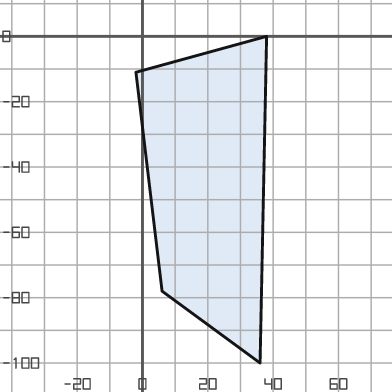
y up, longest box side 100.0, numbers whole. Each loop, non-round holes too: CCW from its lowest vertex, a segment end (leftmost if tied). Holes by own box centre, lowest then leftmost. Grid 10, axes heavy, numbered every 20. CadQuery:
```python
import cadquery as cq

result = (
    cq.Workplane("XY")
    .moveTo(36.0, -100.0)
    .lineTo(38.0, 0.0)
    .lineTo(-2.0, -11.0)
    .lineTo(6.0, -78.0)
    .close()
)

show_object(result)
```